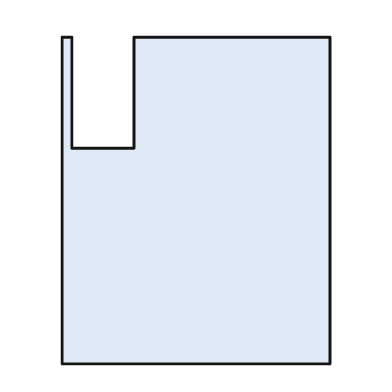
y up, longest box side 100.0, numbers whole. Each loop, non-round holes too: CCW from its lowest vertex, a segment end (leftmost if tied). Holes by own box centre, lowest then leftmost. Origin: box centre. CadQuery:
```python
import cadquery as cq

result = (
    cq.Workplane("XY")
    .moveTo(-41.0, -50.0)
    .lineTo(41.0, -50.0)
    .lineTo(41.0, 50.0)
    .lineTo(-19.0, 50.0)
    .lineTo(-19.0, 16.0)
    .lineTo(-38.0, 16.0)
    .lineTo(-38.0, 50.0)
    .lineTo(-41.0, 50.0)
    .close()
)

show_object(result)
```